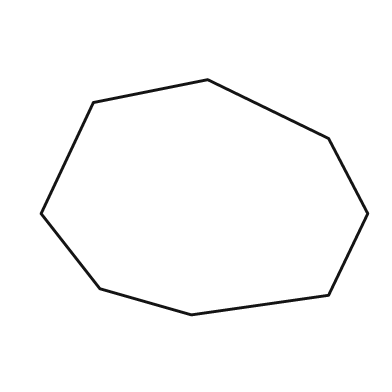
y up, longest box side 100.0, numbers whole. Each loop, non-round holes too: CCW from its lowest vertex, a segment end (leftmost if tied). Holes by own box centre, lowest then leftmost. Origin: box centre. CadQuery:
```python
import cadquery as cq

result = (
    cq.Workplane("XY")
    .moveTo(-4.0, -36.0)
    .lineTo(38.0, -30.0)
    .lineTo(50.0, -5.0)
    .lineTo(38.0, 18.0)
    .lineTo(1.0, 36.0)
    .lineTo(-34.0, 29.0)
    .lineTo(-50.0, -5.0)
    .lineTo(-32.0, -28.0)
    .close()
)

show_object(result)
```